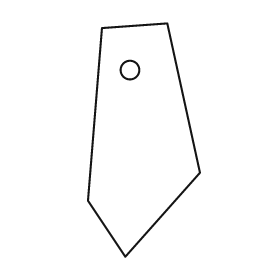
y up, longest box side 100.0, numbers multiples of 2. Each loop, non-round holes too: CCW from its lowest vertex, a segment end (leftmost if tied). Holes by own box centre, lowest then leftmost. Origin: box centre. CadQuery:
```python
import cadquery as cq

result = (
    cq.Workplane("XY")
    .moveTo(-8.0, -50.0)
    .lineTo(24.0, -14.0)
    .lineTo(10.0, 50.0)
    .lineTo(-18.0, 48.0)
    .lineTo(-24.0, -26.0)
    .close()
    .moveTo(-6.0, 30.0)
    .circle(4.0)
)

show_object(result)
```